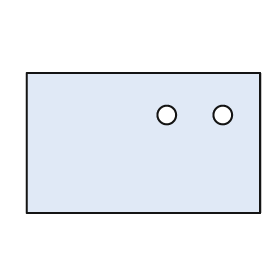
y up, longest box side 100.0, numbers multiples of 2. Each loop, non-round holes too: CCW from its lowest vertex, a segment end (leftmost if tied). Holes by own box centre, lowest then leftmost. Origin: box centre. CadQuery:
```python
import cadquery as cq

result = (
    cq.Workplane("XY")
    .moveTo(-50.0, -30.0)
    .lineTo(50.0, -30.0)
    .lineTo(50.0, 30.0)
    .lineTo(-50.0, 30.0)
    .close()
    .moveTo(10.0, 12.0)
    .circle(4.0)
    .moveTo(34.0, 12.0)
    .circle(4.0)
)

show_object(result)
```